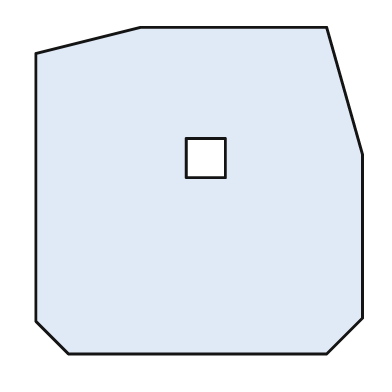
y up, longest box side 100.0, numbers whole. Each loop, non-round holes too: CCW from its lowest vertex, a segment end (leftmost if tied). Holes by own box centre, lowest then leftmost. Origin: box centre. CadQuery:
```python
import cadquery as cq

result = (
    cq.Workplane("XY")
    .moveTo(-40.0, -50.0)
    .lineTo(39.0, -50.0)
    .lineTo(50.0, -39.0)
    .lineTo(50.0, 11.0)
    .lineTo(39.0, 50.0)
    .lineTo(-18.0, 50.0)
    .lineTo(-50.0, 42.0)
    .lineTo(-50.0, -40.0)
    .close()
    .moveTo(-4.0, 4.0)
    .lineTo(8.0, 4.0)
    .lineTo(8.0, 16.0)
    .lineTo(-4.0, 16.0)
    .close()
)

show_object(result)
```